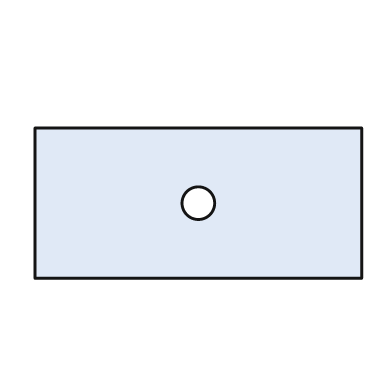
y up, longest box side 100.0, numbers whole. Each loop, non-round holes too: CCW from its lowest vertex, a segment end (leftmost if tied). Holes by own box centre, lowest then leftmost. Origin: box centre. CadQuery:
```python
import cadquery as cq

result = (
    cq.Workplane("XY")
    .moveTo(-50.0, -23.0)
    .lineTo(50.0, -23.0)
    .lineTo(50.0, 23.0)
    .lineTo(-50.0, 23.0)
    .close()
    .moveTo(0.0, 0.0)
    .circle(5.0)
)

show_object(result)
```